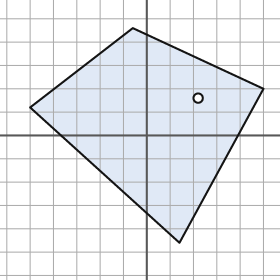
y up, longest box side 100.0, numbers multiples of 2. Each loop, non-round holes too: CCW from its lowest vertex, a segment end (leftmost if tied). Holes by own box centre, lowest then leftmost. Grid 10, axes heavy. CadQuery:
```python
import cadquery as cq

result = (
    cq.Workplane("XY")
    .moveTo(14.0, -46.0)
    .lineTo(50.0, 20.0)
    .lineTo(-6.0, 46.0)
    .lineTo(-50.0, 12.0)
    .close()
    .moveTo(22.0, 16.0)
    .circle(2.0)
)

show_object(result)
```